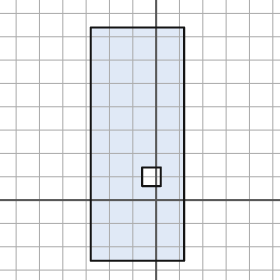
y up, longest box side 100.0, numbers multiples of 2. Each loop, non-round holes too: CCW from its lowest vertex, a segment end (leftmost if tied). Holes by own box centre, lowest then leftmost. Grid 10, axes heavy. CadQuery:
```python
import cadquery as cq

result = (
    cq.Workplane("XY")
    .moveTo(-28.0, -26.0)
    .lineTo(12.0, -26.0)
    .lineTo(12.0, 74.0)
    .lineTo(-28.0, 74.0)
    .close()
    .moveTo(-6.0, 6.0)
    .lineTo(2.0, 6.0)
    .lineTo(2.0, 14.0)
    .lineTo(-6.0, 14.0)
    .close()
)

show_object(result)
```